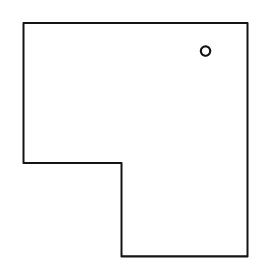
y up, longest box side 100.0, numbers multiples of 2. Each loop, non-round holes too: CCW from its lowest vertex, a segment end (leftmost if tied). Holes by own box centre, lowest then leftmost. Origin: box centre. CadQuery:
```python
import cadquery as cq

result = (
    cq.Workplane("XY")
    .moveTo(-6.0, -50.0)
    .lineTo(48.0, -50.0)
    .lineTo(48.0, 50.0)
    .lineTo(-48.0, 50.0)
    .lineTo(-48.0, -10.0)
    .lineTo(-6.0, -10.0)
    .close()
    .moveTo(30.0, 38.0)
    .circle(2.0)
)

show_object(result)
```